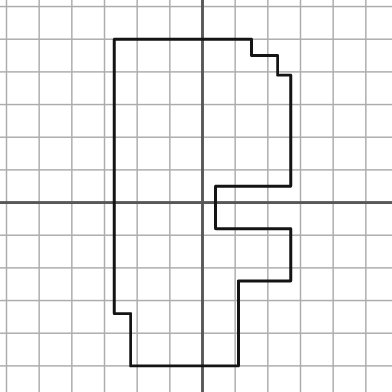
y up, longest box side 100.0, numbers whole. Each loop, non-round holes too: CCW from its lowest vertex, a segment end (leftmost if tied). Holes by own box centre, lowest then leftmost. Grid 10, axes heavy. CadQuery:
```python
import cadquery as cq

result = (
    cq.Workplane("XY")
    .moveTo(-22.0, -50.0)
    .lineTo(11.0, -50.0)
    .lineTo(11.0, -24.0)
    .lineTo(27.0, -24.0)
    .lineTo(27.0, -8.0)
    .lineTo(4.0, -8.0)
    .lineTo(4.0, 5.0)
    .lineTo(27.0, 5.0)
    .lineTo(27.0, 39.0)
    .lineTo(23.0, 39.0)
    .lineTo(23.0, 45.0)
    .lineTo(15.0, 45.0)
    .lineTo(15.0, 50.0)
    .lineTo(-27.0, 50.0)
    .lineTo(-27.0, -34.0)
    .lineTo(-22.0, -34.0)
    .close()
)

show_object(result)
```